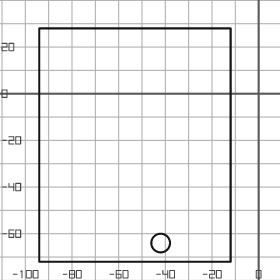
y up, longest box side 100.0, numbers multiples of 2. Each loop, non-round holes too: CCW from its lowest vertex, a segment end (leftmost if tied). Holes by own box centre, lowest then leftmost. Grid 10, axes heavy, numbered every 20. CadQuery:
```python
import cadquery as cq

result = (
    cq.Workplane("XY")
    .moveTo(-94.0, -72.0)
    .lineTo(-12.0, -72.0)
    .lineTo(-12.0, 28.0)
    .lineTo(-94.0, 28.0)
    .close()
    .moveTo(-42.0, -64.0)
    .circle(4.0)
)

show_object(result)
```